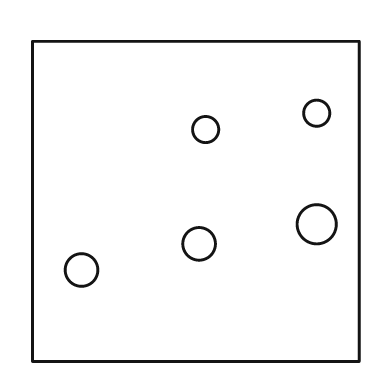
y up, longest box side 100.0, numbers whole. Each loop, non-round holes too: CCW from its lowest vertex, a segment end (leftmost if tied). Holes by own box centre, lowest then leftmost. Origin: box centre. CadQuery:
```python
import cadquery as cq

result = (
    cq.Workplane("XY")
    .moveTo(-50.0, -49.0)
    .lineTo(50.0, -49.0)
    .lineTo(50.0, 49.0)
    .lineTo(-50.0, 49.0)
    .close()
    .moveTo(-35.0, -21.0)
    .circle(5.0)
    .moveTo(1.0, -13.0)
    .circle(5.0)
    .moveTo(37.0, -7.0)
    .circle(6.0)
    .moveTo(3.0, 22.0)
    .circle(4.0)
    .moveTo(37.0, 27.0)
    .circle(4.0)
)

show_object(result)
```